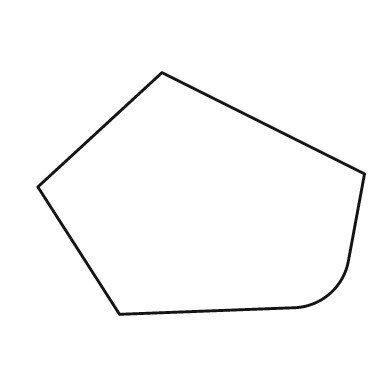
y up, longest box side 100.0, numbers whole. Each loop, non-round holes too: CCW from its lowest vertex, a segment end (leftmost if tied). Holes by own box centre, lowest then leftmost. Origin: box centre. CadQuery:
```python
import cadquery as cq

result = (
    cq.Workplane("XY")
    .moveTo(-25.0, -37.0)
    .lineTo(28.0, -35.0)
    .threePointArc((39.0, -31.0), (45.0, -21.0))
    .lineTo(50.0, 6.0)
    .lineTo(-12.0, 37.0)
    .lineTo(-50.0, 2.0)
    .close()
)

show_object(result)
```